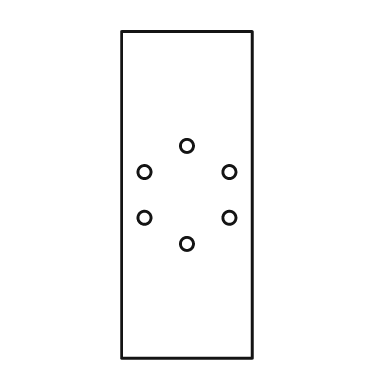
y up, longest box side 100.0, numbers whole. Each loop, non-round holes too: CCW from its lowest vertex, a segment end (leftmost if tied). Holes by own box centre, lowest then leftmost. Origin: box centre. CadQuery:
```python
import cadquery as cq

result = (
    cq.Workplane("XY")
    .moveTo(-20.0, -50.0)
    .lineTo(20.0, -50.0)
    .lineTo(20.0, 50.0)
    .lineTo(-20.0, 50.0)
    .close()
    .moveTo(0.0, -15.0)
    .circle(2.0)
    .moveTo(-13.0, -7.0)
    .circle(2.0)
    .moveTo(13.0, -7.0)
    .circle(2.0)
    .moveTo(-13.0, 7.0)
    .circle(2.0)
    .moveTo(13.0, 7.0)
    .circle(2.0)
    .moveTo(0.0, 15.0)
    .circle(2.0)
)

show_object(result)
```